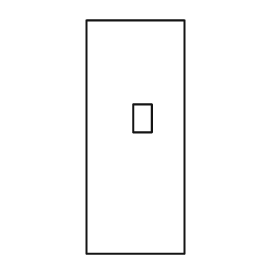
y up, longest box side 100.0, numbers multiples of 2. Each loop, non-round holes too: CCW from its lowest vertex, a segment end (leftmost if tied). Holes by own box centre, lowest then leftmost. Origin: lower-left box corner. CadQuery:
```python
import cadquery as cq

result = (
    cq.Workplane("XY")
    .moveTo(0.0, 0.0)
    .lineTo(42.0, 0.0)
    .lineTo(42.0, 100.0)
    .lineTo(0.0, 100.0)
    .close()
    .moveTo(20.0, 52.0)
    .lineTo(28.0, 52.0)
    .lineTo(28.0, 64.0)
    .lineTo(20.0, 64.0)
    .close()
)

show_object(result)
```